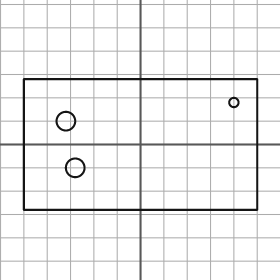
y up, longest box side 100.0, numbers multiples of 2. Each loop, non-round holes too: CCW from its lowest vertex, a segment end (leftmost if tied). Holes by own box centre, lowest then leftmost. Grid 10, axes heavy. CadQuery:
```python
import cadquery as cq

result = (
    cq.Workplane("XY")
    .moveTo(-50.0, -28.0)
    .lineTo(50.0, -28.0)
    .lineTo(50.0, 28.0)
    .lineTo(-50.0, 28.0)
    .close()
    .moveTo(-28.0, -10.0)
    .circle(4.0)
    .moveTo(-32.0, 10.0)
    .circle(4.0)
    .moveTo(40.0, 18.0)
    .circle(2.0)
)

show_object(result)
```